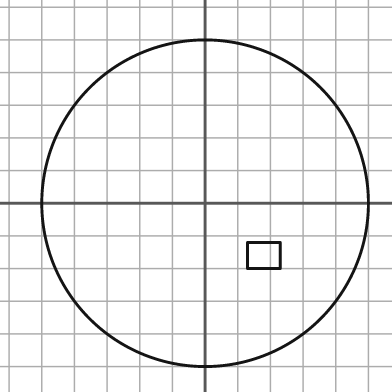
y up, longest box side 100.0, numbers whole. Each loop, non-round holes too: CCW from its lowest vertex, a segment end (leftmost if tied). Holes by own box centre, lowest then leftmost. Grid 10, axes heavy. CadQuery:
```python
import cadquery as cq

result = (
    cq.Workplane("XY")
    .moveTo(0.0, 0.0)
    .circle(50.0)
    .moveTo(13.0, -20.0)
    .lineTo(23.0, -20.0)
    .lineTo(23.0, -12.0)
    .lineTo(13.0, -12.0)
    .close()
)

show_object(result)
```